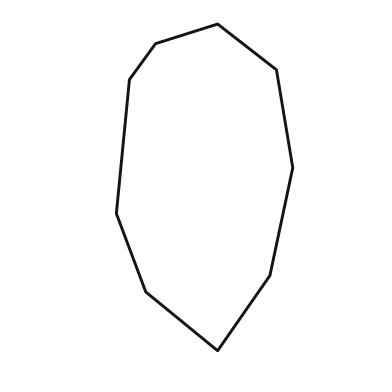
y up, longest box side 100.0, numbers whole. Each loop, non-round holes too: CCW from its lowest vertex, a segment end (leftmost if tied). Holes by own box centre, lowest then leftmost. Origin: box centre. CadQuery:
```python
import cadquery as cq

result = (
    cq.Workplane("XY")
    .moveTo(4.0, -50.0)
    .lineTo(20.0, -27.0)
    .lineTo(27.0, 6.0)
    .lineTo(22.0, 36.0)
    .lineTo(4.0, 50.0)
    .lineTo(-15.0, 44.0)
    .lineTo(-23.0, 33.0)
    .lineTo(-27.0, -8.0)
    .lineTo(-18.0, -32.0)
    .close()
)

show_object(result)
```